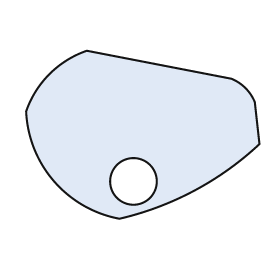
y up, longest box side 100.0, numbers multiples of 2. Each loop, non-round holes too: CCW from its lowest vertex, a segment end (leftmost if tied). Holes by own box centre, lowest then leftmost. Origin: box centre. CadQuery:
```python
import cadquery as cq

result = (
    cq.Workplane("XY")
    .moveTo(-10.0, -36.0)
    .threePointArc((22.0, -24.0), (50.0, -4.0))
    .lineTo(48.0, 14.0)
    .threePointArc((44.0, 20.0), (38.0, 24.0))
    .lineTo(-24.0, 36.0)
    .threePointArc((-40.0, 26.0), (-50.0, 10.0))
    .threePointArc((-38.0, -20.0), (-10.0, -36.0))
    .close()
    .moveTo(-4.0, -20.0)
    .circle(10.0)
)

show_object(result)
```